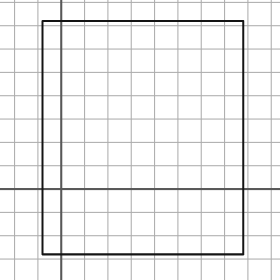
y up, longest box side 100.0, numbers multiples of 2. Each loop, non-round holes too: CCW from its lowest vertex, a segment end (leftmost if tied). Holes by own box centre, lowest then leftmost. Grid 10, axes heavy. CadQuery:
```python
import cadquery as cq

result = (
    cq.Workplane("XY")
    .moveTo(-8.0, -28.0)
    .lineTo(78.0, -28.0)
    .lineTo(78.0, 72.0)
    .lineTo(-8.0, 72.0)
    .close()
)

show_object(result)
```